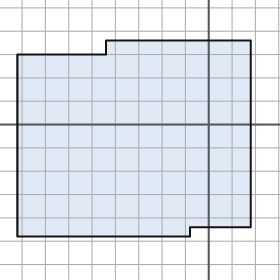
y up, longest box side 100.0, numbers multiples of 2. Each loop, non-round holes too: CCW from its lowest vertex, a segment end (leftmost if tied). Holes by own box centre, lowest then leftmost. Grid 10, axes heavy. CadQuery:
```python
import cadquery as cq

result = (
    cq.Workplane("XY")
    .moveTo(-82.0, -48.0)
    .lineTo(-8.0, -48.0)
    .lineTo(-8.0, -44.0)
    .lineTo(18.0, -44.0)
    .lineTo(18.0, 36.0)
    .lineTo(-44.0, 36.0)
    .lineTo(-44.0, 30.0)
    .lineTo(-82.0, 30.0)
    .close()
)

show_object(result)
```